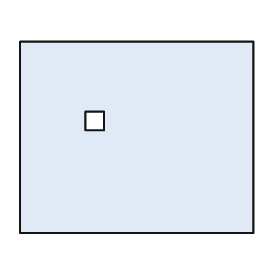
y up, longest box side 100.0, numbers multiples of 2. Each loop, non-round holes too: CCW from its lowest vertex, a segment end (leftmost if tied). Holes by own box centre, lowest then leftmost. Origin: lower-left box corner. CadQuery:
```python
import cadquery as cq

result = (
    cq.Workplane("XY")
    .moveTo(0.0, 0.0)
    .lineTo(100.0, 0.0)
    .lineTo(100.0, 82.0)
    .lineTo(0.0, 82.0)
    .close()
    .moveTo(28.0, 44.0)
    .lineTo(36.0, 44.0)
    .lineTo(36.0, 52.0)
    .lineTo(28.0, 52.0)
    .close()
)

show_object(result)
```